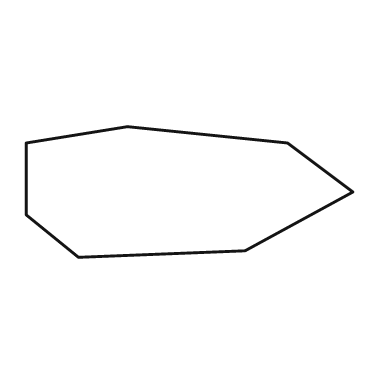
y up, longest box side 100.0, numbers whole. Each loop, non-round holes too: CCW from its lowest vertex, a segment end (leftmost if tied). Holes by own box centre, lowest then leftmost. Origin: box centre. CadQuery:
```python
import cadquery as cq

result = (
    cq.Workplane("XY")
    .moveTo(-34.0, -20.0)
    .lineTo(17.0, -18.0)
    .lineTo(50.0, 0.0)
    .lineTo(30.0, 15.0)
    .lineTo(-19.0, 20.0)
    .lineTo(-50.0, 15.0)
    .lineTo(-50.0, -7.0)
    .close()
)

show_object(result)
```